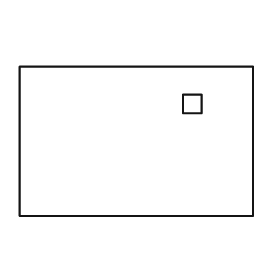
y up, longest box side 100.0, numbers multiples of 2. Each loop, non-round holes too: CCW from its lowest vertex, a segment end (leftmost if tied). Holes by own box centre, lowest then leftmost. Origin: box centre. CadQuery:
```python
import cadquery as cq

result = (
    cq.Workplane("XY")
    .moveTo(-50.0, -32.0)
    .lineTo(50.0, -32.0)
    .lineTo(50.0, 32.0)
    .lineTo(-50.0, 32.0)
    .close()
    .moveTo(20.0, 12.0)
    .lineTo(28.0, 12.0)
    .lineTo(28.0, 20.0)
    .lineTo(20.0, 20.0)
    .close()
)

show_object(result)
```